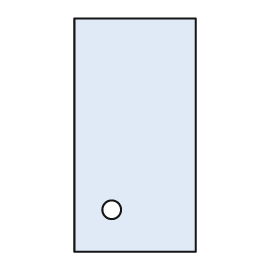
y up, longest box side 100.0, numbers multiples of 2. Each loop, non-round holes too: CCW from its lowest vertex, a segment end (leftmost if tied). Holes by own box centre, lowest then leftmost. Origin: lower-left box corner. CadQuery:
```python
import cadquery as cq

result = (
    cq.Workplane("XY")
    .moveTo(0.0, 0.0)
    .lineTo(52.0, 0.0)
    .lineTo(52.0, 100.0)
    .lineTo(0.0, 100.0)
    .close()
    .moveTo(16.0, 18.0)
    .circle(4.0)
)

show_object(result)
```